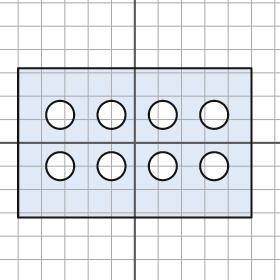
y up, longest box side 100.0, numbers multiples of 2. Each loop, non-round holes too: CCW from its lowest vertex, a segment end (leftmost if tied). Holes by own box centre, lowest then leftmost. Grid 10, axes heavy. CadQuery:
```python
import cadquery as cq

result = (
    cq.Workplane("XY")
    .moveTo(-50.0, -32.0)
    .lineTo(50.0, -32.0)
    .lineTo(50.0, 32.0)
    .lineTo(-50.0, 32.0)
    .close()
    .moveTo(-32.0, -10.0)
    .circle(6.0)
    .moveTo(-10.0, -10.0)
    .circle(6.0)
    .moveTo(12.0, -10.0)
    .circle(6.0)
    .moveTo(34.0, -10.0)
    .circle(6.0)
    .moveTo(-32.0, 12.0)
    .circle(6.0)
    .moveTo(-10.0, 12.0)
    .circle(6.0)
    .moveTo(12.0, 12.0)
    .circle(6.0)
    .moveTo(34.0, 12.0)
    .circle(6.0)
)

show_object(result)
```